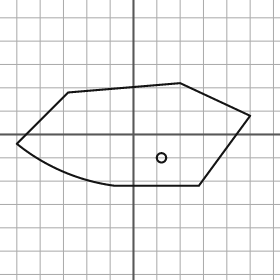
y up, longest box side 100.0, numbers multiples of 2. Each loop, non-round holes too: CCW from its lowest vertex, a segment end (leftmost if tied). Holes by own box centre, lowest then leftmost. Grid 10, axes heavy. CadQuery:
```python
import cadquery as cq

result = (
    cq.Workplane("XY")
    .moveTo(-8.0, -22.0)
    .lineTo(28.0, -22.0)
    .lineTo(50.0, 8.0)
    .lineTo(20.0, 22.0)
    .lineTo(-28.0, 18.0)
    .lineTo(-50.0, -4.0)
    .threePointArc((-30.0, -16.0), (-8.0, -22.0))
    .close()
    .moveTo(12.0, -10.0)
    .circle(2.0)
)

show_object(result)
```